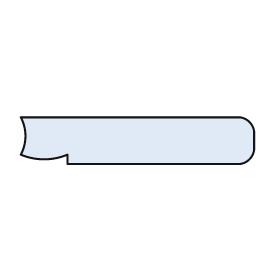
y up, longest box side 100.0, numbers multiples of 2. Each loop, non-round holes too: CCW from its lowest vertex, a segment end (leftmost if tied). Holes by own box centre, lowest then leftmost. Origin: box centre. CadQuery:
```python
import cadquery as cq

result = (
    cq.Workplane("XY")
    .moveTo(-30.0, -10.0)
    .lineTo(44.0, -10.0)
    .threePointArc((48.0, -8.0), (50.0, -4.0))
    .lineTo(50.0, 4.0)
    .threePointArc((48.0, 8.0), (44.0, 10.0))
    .lineTo(-50.0, 10.0)
    .threePointArc((-48.0, 2.0), (-50.0, -6.0))
    .threePointArc((-40.0, -8.0), (-30.0, -6.0))
    .close()
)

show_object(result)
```